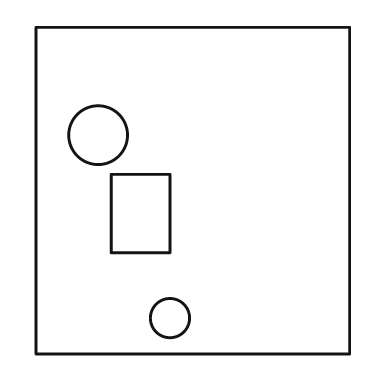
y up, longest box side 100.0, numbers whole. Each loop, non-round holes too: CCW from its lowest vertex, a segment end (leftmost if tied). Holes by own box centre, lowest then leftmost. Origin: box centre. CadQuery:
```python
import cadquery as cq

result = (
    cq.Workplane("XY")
    .moveTo(-48.0, -50.0)
    .lineTo(48.0, -50.0)
    .lineTo(48.0, 50.0)
    .lineTo(-48.0, 50.0)
    .close()
    .moveTo(-7.0, -39.0)
    .circle(6.0)
    .moveTo(-25.0, -19.0)
    .lineTo(-7.0, -19.0)
    .lineTo(-7.0, 5.0)
    .lineTo(-25.0, 5.0)
    .close()
    .moveTo(-29.0, 17.0)
    .circle(9.0)
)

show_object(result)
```